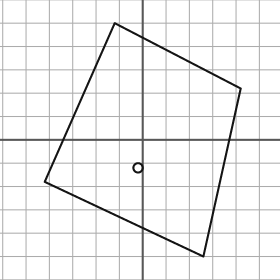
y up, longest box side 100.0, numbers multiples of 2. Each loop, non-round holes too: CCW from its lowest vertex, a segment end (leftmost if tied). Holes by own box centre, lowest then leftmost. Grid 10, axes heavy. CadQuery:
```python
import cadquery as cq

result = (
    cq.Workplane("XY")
    .moveTo(26.0, -50.0)
    .lineTo(42.0, 22.0)
    .lineTo(-12.0, 50.0)
    .lineTo(-42.0, -18.0)
    .close()
    .moveTo(-2.0, -12.0)
    .circle(2.0)
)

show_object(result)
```